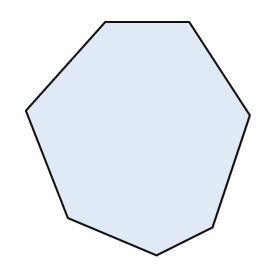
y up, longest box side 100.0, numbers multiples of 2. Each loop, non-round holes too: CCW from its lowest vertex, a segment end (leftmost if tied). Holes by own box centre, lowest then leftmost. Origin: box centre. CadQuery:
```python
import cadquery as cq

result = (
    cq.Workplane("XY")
    .moveTo(8.0, -50.0)
    .lineTo(32.0, -38.0)
    .lineTo(48.0, 10.0)
    .lineTo(22.0, 50.0)
    .lineTo(-14.0, 50.0)
    .lineTo(-48.0, 12.0)
    .lineTo(-30.0, -34.0)
    .close()
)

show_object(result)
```